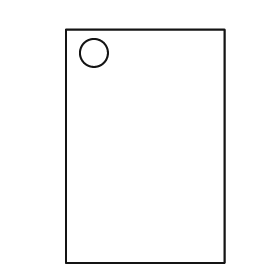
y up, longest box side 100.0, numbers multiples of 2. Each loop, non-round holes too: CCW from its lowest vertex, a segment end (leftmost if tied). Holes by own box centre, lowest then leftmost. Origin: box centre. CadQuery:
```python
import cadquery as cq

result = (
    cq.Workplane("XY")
    .moveTo(-34.0, -50.0)
    .lineTo(34.0, -50.0)
    .lineTo(34.0, 50.0)
    .lineTo(-34.0, 50.0)
    .close()
    .moveTo(-22.0, 40.0)
    .circle(6.0)
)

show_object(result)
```